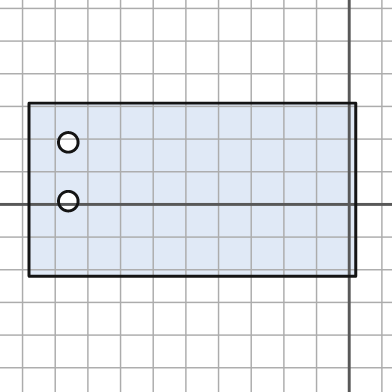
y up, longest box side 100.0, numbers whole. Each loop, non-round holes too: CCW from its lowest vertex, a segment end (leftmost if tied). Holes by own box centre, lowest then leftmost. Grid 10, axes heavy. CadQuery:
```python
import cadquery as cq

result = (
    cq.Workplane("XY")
    .moveTo(-98.0, -22.0)
    .lineTo(2.0, -22.0)
    .lineTo(2.0, 31.0)
    .lineTo(-98.0, 31.0)
    .close()
    .moveTo(-86.0, 1.0)
    .circle(3.0)
    .moveTo(-86.0, 19.0)
    .circle(3.0)
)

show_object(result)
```